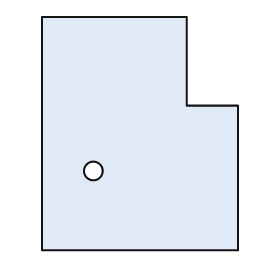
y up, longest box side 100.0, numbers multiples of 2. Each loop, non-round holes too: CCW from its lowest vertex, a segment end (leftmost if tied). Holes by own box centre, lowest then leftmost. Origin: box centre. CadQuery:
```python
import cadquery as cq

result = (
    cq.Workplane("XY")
    .moveTo(-42.0, -50.0)
    .lineTo(42.0, -50.0)
    .lineTo(42.0, 12.0)
    .lineTo(20.0, 12.0)
    .lineTo(20.0, 50.0)
    .lineTo(-42.0, 50.0)
    .close()
    .moveTo(-20.0, -16.0)
    .circle(4.0)
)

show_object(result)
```